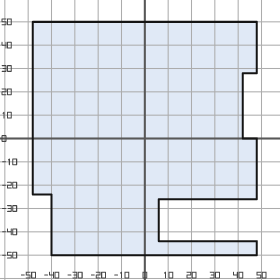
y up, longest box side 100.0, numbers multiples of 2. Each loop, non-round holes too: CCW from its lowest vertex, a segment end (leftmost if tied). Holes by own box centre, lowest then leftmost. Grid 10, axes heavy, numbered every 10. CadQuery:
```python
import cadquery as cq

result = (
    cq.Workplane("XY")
    .moveTo(-40.0, -50.0)
    .lineTo(48.0, -50.0)
    .lineTo(48.0, -44.0)
    .lineTo(6.0, -44.0)
    .lineTo(6.0, -26.0)
    .lineTo(48.0, -26.0)
    .lineTo(48.0, 0.0)
    .lineTo(42.0, 0.0)
    .lineTo(42.0, 28.0)
    .lineTo(48.0, 28.0)
    .lineTo(48.0, 50.0)
    .lineTo(-48.0, 50.0)
    .lineTo(-48.0, -24.0)
    .lineTo(-40.0, -24.0)
    .close()
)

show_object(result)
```